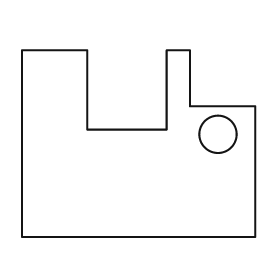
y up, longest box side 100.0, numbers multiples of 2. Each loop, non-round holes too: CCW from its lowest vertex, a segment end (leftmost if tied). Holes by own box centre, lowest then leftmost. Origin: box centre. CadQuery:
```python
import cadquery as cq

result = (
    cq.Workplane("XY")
    .moveTo(-50.0, -40.0)
    .lineTo(50.0, -40.0)
    .lineTo(50.0, 16.0)
    .lineTo(22.0, 16.0)
    .lineTo(22.0, 40.0)
    .lineTo(12.0, 40.0)
    .lineTo(12.0, 6.0)
    .lineTo(-22.0, 6.0)
    .lineTo(-22.0, 40.0)
    .lineTo(-50.0, 40.0)
    .close()
    .moveTo(34.0, 4.0)
    .circle(8.0)
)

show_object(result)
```